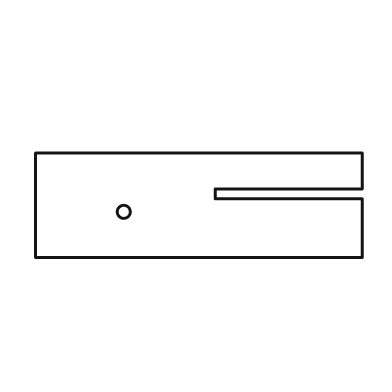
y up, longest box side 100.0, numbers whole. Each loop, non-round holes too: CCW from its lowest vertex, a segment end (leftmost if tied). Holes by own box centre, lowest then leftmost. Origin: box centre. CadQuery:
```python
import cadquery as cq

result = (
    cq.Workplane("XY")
    .moveTo(-50.0, -16.0)
    .lineTo(50.0, -16.0)
    .lineTo(50.0, 2.0)
    .lineTo(5.0, 2.0)
    .lineTo(5.0, 5.0)
    .lineTo(50.0, 5.0)
    .lineTo(50.0, 16.0)
    .lineTo(-50.0, 16.0)
    .close()
    .moveTo(-23.0, -2.0)
    .circle(2.0)
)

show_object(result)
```